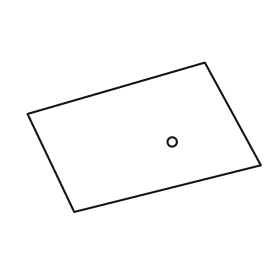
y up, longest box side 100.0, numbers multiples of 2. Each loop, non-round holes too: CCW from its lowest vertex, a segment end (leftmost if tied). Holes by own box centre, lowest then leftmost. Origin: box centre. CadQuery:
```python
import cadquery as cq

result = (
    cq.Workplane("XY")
    .moveTo(-30.0, -32.0)
    .lineTo(50.0, -12.0)
    .lineTo(26.0, 32.0)
    .lineTo(-50.0, 10.0)
    .close()
    .moveTo(12.0, -2.0)
    .circle(2.0)
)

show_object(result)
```